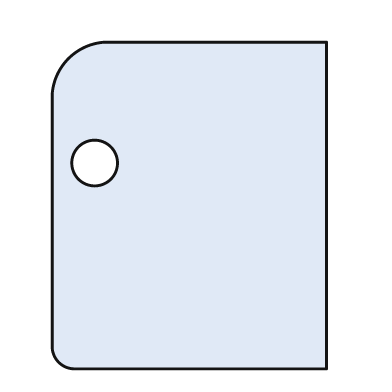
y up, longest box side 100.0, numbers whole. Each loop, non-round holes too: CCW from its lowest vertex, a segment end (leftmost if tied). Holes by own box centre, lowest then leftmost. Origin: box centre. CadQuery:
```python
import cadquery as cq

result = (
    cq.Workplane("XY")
    .moveTo(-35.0, -50.0)
    .lineTo(42.0, -50.0)
    .lineTo(42.0, 50.0)
    .lineTo(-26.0, 50.0)
    .threePointArc((-37.0, 45.0), (-42.0, 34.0))
    .lineTo(-42.0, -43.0)
    .threePointArc((-40.0, -48.0), (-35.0, -50.0))
    .close()
    .moveTo(-29.0, 13.0)
    .circle(7.0)
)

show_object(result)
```